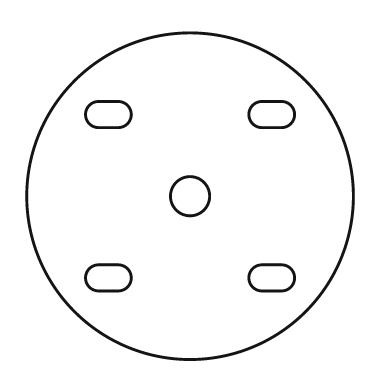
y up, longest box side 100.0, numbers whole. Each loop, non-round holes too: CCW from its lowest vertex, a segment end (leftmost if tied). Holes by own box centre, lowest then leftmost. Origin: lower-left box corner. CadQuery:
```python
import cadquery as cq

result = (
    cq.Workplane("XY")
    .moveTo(50.0, 50.0)
    .circle(50.0)
    .moveTo(22.0, 21.0)
    .lineTo(28.0, 21.0)
    .threePointArc((32.0, 25.0), (28.0, 29.0))
    .lineTo(22.0, 29.0)
    .threePointArc((18.0, 25.0), (22.0, 21.0))
    .close()
    .moveTo(72.0, 21.0)
    .lineTo(78.0, 21.0)
    .threePointArc((82.0, 25.0), (78.0, 29.0))
    .lineTo(72.0, 29.0)
    .threePointArc((68.0, 25.0), (72.0, 21.0))
    .close()
    .moveTo(50.0, 50.0)
    .circle(6.0)
    .moveTo(22.0, 71.0)
    .lineTo(28.0, 71.0)
    .threePointArc((32.0, 75.0), (28.0, 79.0))
    .lineTo(22.0, 79.0)
    .threePointArc((18.0, 75.0), (22.0, 71.0))
    .close()
    .moveTo(72.0, 71.0)
    .lineTo(78.0, 71.0)
    .threePointArc((82.0, 75.0), (78.0, 79.0))
    .lineTo(72.0, 79.0)
    .threePointArc((68.0, 75.0), (72.0, 71.0))
    .close()
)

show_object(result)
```